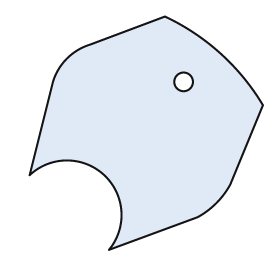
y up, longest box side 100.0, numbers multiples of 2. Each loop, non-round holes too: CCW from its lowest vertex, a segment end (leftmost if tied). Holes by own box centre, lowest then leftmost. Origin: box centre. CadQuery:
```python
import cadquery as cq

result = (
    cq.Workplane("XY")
    .moveTo(-16.0, -50.0)
    .lineTo(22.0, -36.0)
    .threePointArc((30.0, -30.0), (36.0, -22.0))
    .lineTo(50.0, 12.0)
    .threePointArc((32.0, 34.0), (8.0, 50.0))
    .lineTo(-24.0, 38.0)
    .threePointArc((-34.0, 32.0), (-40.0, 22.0))
    .lineTo(-50.0, -18.0)
    .threePointArc((-18.0, -18.0), (-16.0, -50.0))
    .close()
    .moveTo(16.0, 22.0)
    .circle(4.0)
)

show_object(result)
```